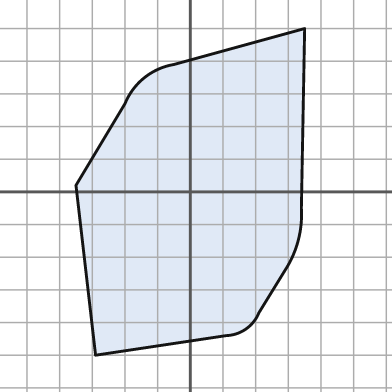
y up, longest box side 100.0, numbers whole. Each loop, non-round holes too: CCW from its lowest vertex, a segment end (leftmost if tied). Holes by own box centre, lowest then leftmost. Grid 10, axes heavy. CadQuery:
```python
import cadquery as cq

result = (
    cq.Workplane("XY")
    .moveTo(-29.0, -50.0)
    .lineTo(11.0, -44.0)
    .threePointArc((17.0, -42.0), (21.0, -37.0))
    .lineTo(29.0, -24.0)
    .threePointArc((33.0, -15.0), (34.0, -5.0))
    .lineTo(35.0, 50.0)
    .lineTo(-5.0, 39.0)
    .threePointArc((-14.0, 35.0), (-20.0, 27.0))
    .lineTo(-35.0, 2.0)
    .close()
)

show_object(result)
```